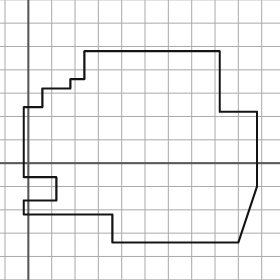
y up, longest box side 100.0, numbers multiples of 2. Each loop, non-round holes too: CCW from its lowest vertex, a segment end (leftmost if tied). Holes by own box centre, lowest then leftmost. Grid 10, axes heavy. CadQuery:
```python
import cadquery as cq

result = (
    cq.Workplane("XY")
    .moveTo(36.0, -34.0)
    .lineTo(90.0, -34.0)
    .lineTo(98.0, -10.0)
    .lineTo(98.0, 22.0)
    .lineTo(82.0, 22.0)
    .lineTo(82.0, 48.0)
    .lineTo(24.0, 48.0)
    .lineTo(24.0, 36.0)
    .lineTo(18.0, 36.0)
    .lineTo(18.0, 32.0)
    .lineTo(6.0, 32.0)
    .lineTo(6.0, 24.0)
    .lineTo(-2.0, 24.0)
    .lineTo(-2.0, -6.0)
    .lineTo(12.0, -6.0)
    .lineTo(12.0, -16.0)
    .lineTo(-2.0, -16.0)
    .lineTo(-2.0, -22.0)
    .lineTo(36.0, -22.0)
    .close()
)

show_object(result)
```